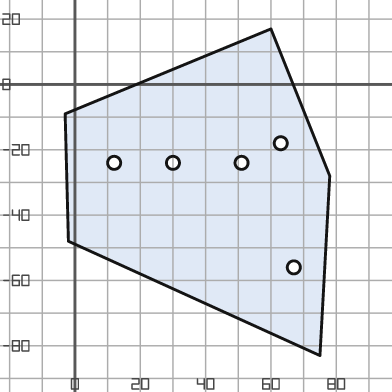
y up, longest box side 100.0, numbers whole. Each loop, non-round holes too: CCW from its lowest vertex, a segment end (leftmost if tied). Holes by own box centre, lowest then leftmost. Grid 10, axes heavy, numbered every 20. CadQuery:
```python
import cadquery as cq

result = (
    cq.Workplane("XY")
    .moveTo(75.0, -83.0)
    .lineTo(78.0, -28.0)
    .lineTo(60.0, 17.0)
    .lineTo(-3.0, -9.0)
    .lineTo(-2.0, -48.0)
    .close()
    .moveTo(67.0, -56.0)
    .circle(2.0)
    .moveTo(12.0, -24.0)
    .circle(2.0)
    .moveTo(30.0, -24.0)
    .circle(2.0)
    .moveTo(51.0, -24.0)
    .circle(2.0)
    .moveTo(63.0, -18.0)
    .circle(2.0)
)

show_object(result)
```